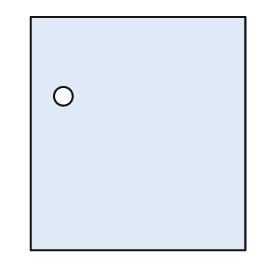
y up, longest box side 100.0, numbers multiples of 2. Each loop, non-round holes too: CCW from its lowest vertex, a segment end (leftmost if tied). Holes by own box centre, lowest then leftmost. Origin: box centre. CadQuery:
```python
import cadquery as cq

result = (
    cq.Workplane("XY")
    .moveTo(-46.0, -50.0)
    .lineTo(46.0, -50.0)
    .lineTo(46.0, 50.0)
    .lineTo(-46.0, 50.0)
    .close()
    .moveTo(-32.0, 16.0)
    .circle(4.0)
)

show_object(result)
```